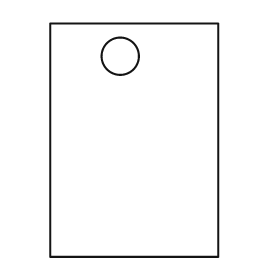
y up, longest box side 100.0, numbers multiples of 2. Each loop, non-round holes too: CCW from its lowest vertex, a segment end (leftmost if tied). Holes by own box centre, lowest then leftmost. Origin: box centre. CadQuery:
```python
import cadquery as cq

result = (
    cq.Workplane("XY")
    .moveTo(-36.0, -50.0)
    .lineTo(36.0, -50.0)
    .lineTo(36.0, 50.0)
    .lineTo(-36.0, 50.0)
    .close()
    .moveTo(-6.0, 36.0)
    .circle(8.0)
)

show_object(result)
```